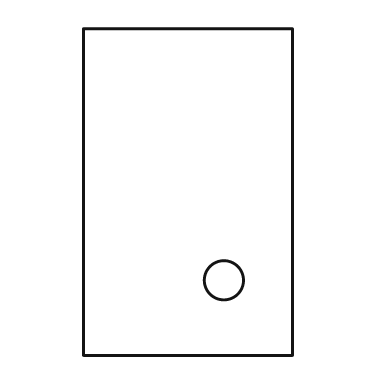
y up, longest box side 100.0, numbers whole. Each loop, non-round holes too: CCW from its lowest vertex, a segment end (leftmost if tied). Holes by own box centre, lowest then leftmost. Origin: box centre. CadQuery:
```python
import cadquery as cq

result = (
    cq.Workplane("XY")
    .moveTo(-32.0, -50.0)
    .lineTo(32.0, -50.0)
    .lineTo(32.0, 50.0)
    .lineTo(-32.0, 50.0)
    .close()
    .moveTo(11.0, -27.0)
    .circle(6.0)
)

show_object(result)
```